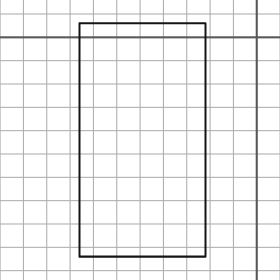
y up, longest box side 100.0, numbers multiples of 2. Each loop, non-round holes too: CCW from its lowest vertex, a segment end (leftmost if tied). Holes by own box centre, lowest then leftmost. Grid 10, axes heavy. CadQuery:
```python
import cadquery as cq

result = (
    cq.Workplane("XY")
    .moveTo(-76.0, -94.0)
    .lineTo(-22.0, -94.0)
    .lineTo(-22.0, 6.0)
    .lineTo(-76.0, 6.0)
    .close()
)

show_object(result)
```